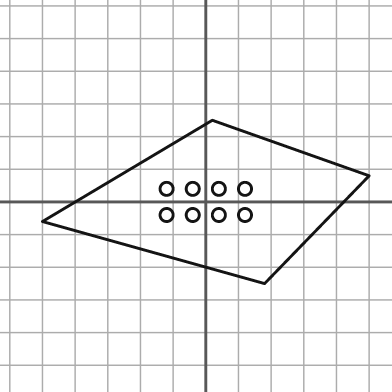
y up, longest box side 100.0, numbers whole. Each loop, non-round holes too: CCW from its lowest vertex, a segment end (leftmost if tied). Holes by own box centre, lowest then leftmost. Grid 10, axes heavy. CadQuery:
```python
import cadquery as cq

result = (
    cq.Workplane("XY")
    .moveTo(18.0, -25.0)
    .lineTo(50.0, 8.0)
    .lineTo(2.0, 25.0)
    .lineTo(-50.0, -6.0)
    .close()
    .moveTo(-12.0, -4.0)
    .circle(2.0)
    .moveTo(-4.0, -4.0)
    .circle(2.0)
    .moveTo(4.0, -4.0)
    .circle(2.0)
    .moveTo(12.0, -4.0)
    .circle(2.0)
    .moveTo(-12.0, 4.0)
    .circle(2.0)
    .moveTo(-4.0, 4.0)
    .circle(2.0)
    .moveTo(4.0, 4.0)
    .circle(2.0)
    .moveTo(12.0, 4.0)
    .circle(2.0)
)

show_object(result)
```